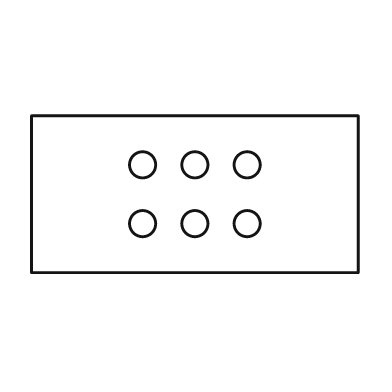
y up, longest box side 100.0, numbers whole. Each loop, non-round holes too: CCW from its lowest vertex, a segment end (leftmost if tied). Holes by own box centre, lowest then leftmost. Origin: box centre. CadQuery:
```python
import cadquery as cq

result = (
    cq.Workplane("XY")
    .moveTo(-50.0, -24.0)
    .lineTo(50.0, -24.0)
    .lineTo(50.0, 24.0)
    .lineTo(-50.0, 24.0)
    .close()
    .moveTo(-16.0, -9.0)
    .circle(4.0)
    .moveTo(0.0, -9.0)
    .circle(4.0)
    .moveTo(16.0, -9.0)
    .circle(4.0)
    .moveTo(-16.0, 9.0)
    .circle(4.0)
    .moveTo(0.0, 9.0)
    .circle(4.0)
    .moveTo(16.0, 9.0)
    .circle(4.0)
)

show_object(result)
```